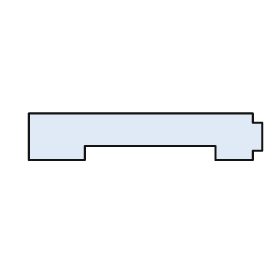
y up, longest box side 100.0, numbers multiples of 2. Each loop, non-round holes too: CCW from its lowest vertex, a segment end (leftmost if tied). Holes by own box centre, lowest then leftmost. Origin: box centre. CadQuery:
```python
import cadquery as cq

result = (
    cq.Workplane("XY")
    .moveTo(-50.0, -10.0)
    .lineTo(-26.0, -10.0)
    .lineTo(-26.0, -4.0)
    .lineTo(30.0, -4.0)
    .lineTo(30.0, -10.0)
    .lineTo(46.0, -10.0)
    .lineTo(46.0, -6.0)
    .lineTo(50.0, -6.0)
    .lineTo(50.0, 6.0)
    .lineTo(46.0, 6.0)
    .lineTo(46.0, 10.0)
    .lineTo(-50.0, 10.0)
    .close()
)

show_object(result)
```